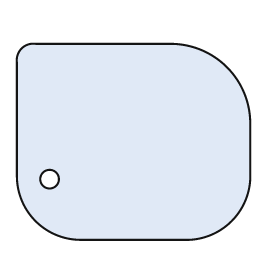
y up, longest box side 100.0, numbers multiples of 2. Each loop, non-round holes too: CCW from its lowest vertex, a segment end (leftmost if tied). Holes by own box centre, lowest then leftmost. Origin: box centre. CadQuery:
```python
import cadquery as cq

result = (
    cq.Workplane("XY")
    .moveTo(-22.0, -42.0)
    .lineTo(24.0, -42.0)
    .threePointArc((42.0, -34.0), (50.0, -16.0))
    .lineTo(50.0, 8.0)
    .threePointArc((40.0, 32.0), (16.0, 42.0))
    .lineTo(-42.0, 42.0)
    .threePointArc((-48.0, 40.0), (-50.0, 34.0))
    .lineTo(-50.0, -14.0)
    .threePointArc((-42.0, -34.0), (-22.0, -42.0))
    .close()
    .moveTo(-36.0, -16.0)
    .circle(4.0)
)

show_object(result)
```